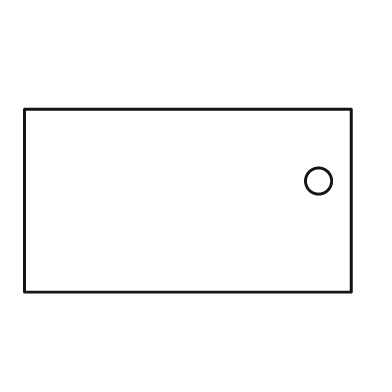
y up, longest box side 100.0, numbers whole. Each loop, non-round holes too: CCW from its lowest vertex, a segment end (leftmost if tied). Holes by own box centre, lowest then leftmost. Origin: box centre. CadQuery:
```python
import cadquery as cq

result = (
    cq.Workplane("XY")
    .moveTo(-50.0, -28.0)
    .lineTo(50.0, -28.0)
    .lineTo(50.0, 28.0)
    .lineTo(-50.0, 28.0)
    .close()
    .moveTo(40.0, 6.0)
    .circle(4.0)
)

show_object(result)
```